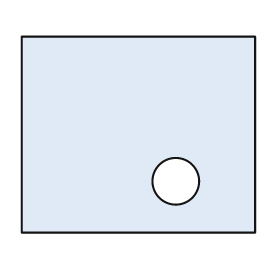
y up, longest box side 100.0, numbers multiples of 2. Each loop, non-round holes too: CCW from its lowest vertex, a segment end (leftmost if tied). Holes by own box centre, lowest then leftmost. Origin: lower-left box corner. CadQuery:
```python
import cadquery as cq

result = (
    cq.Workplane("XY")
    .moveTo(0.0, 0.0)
    .lineTo(100.0, 0.0)
    .lineTo(100.0, 84.0)
    .lineTo(0.0, 84.0)
    .close()
    .moveTo(66.0, 22.0)
    .circle(10.0)
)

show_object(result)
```